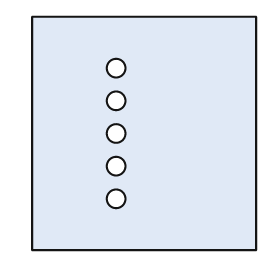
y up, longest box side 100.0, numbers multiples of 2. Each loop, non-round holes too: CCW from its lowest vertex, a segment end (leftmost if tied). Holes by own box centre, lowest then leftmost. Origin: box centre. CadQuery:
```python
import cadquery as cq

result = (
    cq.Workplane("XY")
    .moveTo(-48.0, -50.0)
    .lineTo(48.0, -50.0)
    .lineTo(48.0, 50.0)
    .lineTo(-48.0, 50.0)
    .close()
    .moveTo(-12.0, -28.0)
    .circle(4.0)
    .moveTo(-12.0, -14.0)
    .circle(4.0)
    .moveTo(-12.0, 0.0)
    .circle(4.0)
    .moveTo(-12.0, 14.0)
    .circle(4.0)
    .moveTo(-12.0, 28.0)
    .circle(4.0)
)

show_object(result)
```